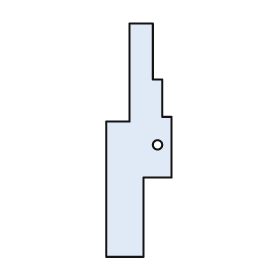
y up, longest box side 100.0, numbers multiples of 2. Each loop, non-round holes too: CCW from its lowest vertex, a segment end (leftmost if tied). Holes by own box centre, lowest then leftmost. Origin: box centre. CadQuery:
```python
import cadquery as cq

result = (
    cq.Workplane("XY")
    .moveTo(-14.0, -50.0)
    .lineTo(2.0, -50.0)
    .lineTo(2.0, -16.0)
    .lineTo(14.0, -16.0)
    .lineTo(14.0, 10.0)
    .lineTo(10.0, 10.0)
    .lineTo(10.0, 26.0)
    .lineTo(6.0, 26.0)
    .lineTo(6.0, 50.0)
    .lineTo(-4.0, 50.0)
    .lineTo(-4.0, 8.0)
    .lineTo(-14.0, 8.0)
    .close()
    .moveTo(8.0, -2.0)
    .circle(2.0)
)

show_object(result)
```